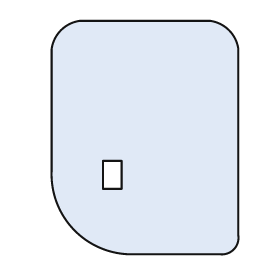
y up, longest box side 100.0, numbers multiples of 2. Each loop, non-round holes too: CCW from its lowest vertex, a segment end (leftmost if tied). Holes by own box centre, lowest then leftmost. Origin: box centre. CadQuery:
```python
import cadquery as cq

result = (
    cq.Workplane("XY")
    .moveTo(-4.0, -50.0)
    .lineTo(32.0, -50.0)
    .threePointArc((38.0, -48.0), (40.0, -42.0))
    .lineTo(40.0, 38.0)
    .threePointArc((36.0, 46.0), (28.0, 50.0))
    .lineTo(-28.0, 50.0)
    .threePointArc((-36.0, 46.0), (-40.0, 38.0))
    .lineTo(-40.0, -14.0)
    .threePointArc((-30.0, -40.0), (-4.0, -50.0))
    .close()
    .moveTo(-18.0, -22.0)
    .lineTo(-10.0, -22.0)
    .lineTo(-10.0, -10.0)
    .lineTo(-18.0, -10.0)
    .close()
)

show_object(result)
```